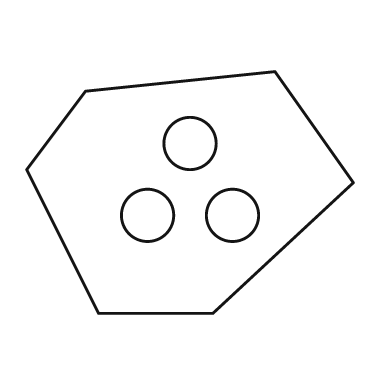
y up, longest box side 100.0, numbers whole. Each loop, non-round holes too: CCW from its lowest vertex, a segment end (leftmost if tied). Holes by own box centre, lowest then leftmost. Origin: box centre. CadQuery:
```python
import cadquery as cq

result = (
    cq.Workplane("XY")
    .moveTo(-28.0, -37.0)
    .lineTo(7.0, -37.0)
    .lineTo(50.0, 3.0)
    .lineTo(26.0, 37.0)
    .lineTo(-32.0, 31.0)
    .lineTo(-50.0, 7.0)
    .close()
    .moveTo(-13.0, -7.0)
    .circle(8.0)
    .moveTo(13.0, -7.0)
    .circle(8.0)
    .moveTo(0.0, 15.0)
    .circle(8.0)
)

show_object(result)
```